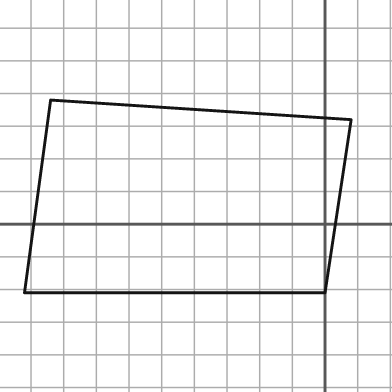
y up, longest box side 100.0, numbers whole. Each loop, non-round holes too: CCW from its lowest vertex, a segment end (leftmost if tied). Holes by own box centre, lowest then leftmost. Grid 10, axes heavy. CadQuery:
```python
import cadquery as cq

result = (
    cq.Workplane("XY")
    .moveTo(-92.0, -21.0)
    .lineTo(0.0, -21.0)
    .lineTo(8.0, 32.0)
    .lineTo(-84.0, 38.0)
    .close()
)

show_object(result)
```